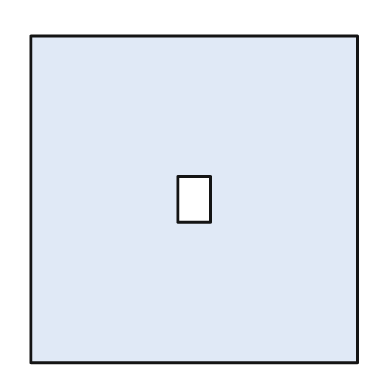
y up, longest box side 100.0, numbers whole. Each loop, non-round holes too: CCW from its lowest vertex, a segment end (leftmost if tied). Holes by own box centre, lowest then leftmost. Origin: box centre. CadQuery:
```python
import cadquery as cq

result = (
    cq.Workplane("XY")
    .moveTo(-50.0, -50.0)
    .lineTo(50.0, -50.0)
    .lineTo(50.0, 50.0)
    .lineTo(-50.0, 50.0)
    .close()
    .moveTo(-5.0, -7.0)
    .lineTo(5.0, -7.0)
    .lineTo(5.0, 7.0)
    .lineTo(-5.0, 7.0)
    .close()
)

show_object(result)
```